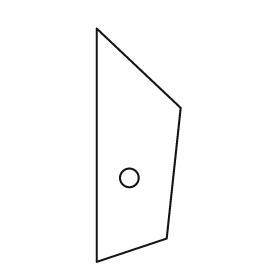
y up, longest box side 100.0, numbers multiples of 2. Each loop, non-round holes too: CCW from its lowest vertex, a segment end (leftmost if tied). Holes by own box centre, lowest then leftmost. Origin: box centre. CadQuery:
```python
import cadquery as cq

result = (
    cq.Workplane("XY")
    .moveTo(-18.0, -50.0)
    .lineTo(12.0, -40.0)
    .lineTo(18.0, 16.0)
    .lineTo(-18.0, 50.0)
    .close()
    .moveTo(-4.0, -14.0)
    .circle(4.0)
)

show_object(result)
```